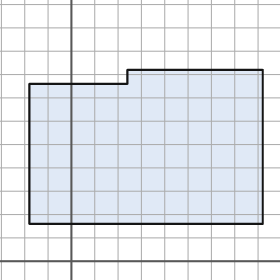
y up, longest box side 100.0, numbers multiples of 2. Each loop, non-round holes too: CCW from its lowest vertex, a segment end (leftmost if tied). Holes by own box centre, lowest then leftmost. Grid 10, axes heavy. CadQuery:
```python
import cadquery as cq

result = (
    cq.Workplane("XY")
    .moveTo(-18.0, 16.0)
    .lineTo(82.0, 16.0)
    .lineTo(82.0, 82.0)
    .lineTo(24.0, 82.0)
    .lineTo(24.0, 76.0)
    .lineTo(-18.0, 76.0)
    .close()
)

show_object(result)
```